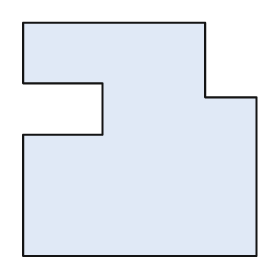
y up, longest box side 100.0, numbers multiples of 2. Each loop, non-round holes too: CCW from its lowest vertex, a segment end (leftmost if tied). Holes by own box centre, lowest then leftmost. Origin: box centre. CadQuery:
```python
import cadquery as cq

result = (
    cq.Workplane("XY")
    .moveTo(-50.0, -50.0)
    .lineTo(50.0, -50.0)
    .lineTo(50.0, 18.0)
    .lineTo(28.0, 18.0)
    .lineTo(28.0, 50.0)
    .lineTo(-50.0, 50.0)
    .lineTo(-50.0, 24.0)
    .lineTo(-16.0, 24.0)
    .lineTo(-16.0, 2.0)
    .lineTo(-50.0, 2.0)
    .close()
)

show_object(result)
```